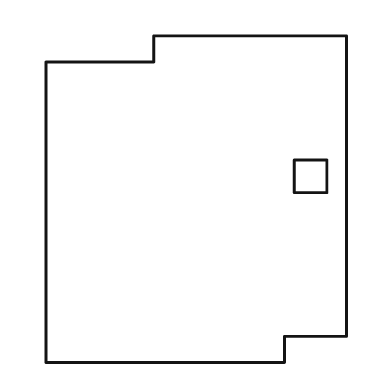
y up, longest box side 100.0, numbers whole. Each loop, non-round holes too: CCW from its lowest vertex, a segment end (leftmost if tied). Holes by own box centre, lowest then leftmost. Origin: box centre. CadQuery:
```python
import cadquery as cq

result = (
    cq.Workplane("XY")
    .moveTo(-46.0, -50.0)
    .lineTo(27.0, -50.0)
    .lineTo(27.0, -42.0)
    .lineTo(46.0, -42.0)
    .lineTo(46.0, 50.0)
    .lineTo(-13.0, 50.0)
    .lineTo(-13.0, 42.0)
    .lineTo(-46.0, 42.0)
    .close()
    .moveTo(30.0, 2.0)
    .lineTo(40.0, 2.0)
    .lineTo(40.0, 12.0)
    .lineTo(30.0, 12.0)
    .close()
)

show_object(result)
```